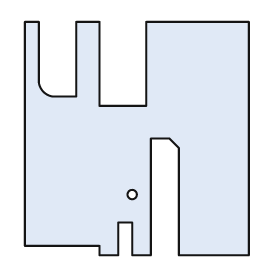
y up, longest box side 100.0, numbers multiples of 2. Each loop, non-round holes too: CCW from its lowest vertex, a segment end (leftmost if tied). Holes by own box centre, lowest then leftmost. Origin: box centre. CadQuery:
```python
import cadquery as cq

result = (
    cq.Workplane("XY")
    .moveTo(-16.0, -50.0)
    .lineTo(-8.0, -50.0)
    .lineTo(-8.0, -36.0)
    .lineTo(-2.0, -36.0)
    .lineTo(-2.0, -50.0)
    .lineTo(6.0, -50.0)
    .lineTo(6.0, 0.0)
    .lineTo(14.0, 0.0)
    .lineTo(18.0, -4.0)
    .lineTo(18.0, -50.0)
    .lineTo(48.0, -50.0)
    .lineTo(48.0, 50.0)
    .lineTo(4.0, 50.0)
    .lineTo(4.0, 14.0)
    .lineTo(-16.0, 14.0)
    .lineTo(-16.0, 50.0)
    .lineTo(-26.0, 50.0)
    .lineTo(-26.0, 18.0)
    .lineTo(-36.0, 18.0)
    .threePointArc((-40.0, 20.0), (-42.0, 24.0))
    .lineTo(-42.0, 50.0)
    .lineTo(-48.0, 50.0)
    .lineTo(-48.0, -46.0)
    .lineTo(-16.0, -46.0)
    .close()
    .moveTo(-2.0, -24.0)
    .circle(2.0)
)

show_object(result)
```